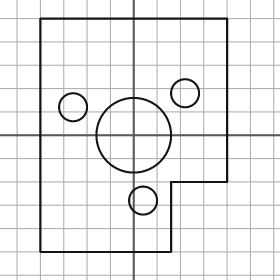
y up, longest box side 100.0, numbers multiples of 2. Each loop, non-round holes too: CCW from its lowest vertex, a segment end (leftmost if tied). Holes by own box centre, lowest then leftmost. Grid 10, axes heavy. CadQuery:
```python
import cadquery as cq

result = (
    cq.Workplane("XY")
    .moveTo(-40.0, -50.0)
    .lineTo(16.0, -50.0)
    .lineTo(16.0, -20.0)
    .lineTo(40.0, -20.0)
    .lineTo(40.0, 50.0)
    .lineTo(-40.0, 50.0)
    .close()
    .moveTo(4.0, -28.0)
    .circle(6.0)
    .moveTo(0.0, 0.0)
    .circle(16.0)
    .moveTo(-26.0, 12.0)
    .circle(6.0)
    .moveTo(22.0, 18.0)
    .circle(6.0)
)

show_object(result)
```